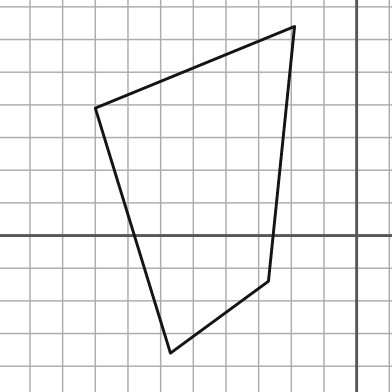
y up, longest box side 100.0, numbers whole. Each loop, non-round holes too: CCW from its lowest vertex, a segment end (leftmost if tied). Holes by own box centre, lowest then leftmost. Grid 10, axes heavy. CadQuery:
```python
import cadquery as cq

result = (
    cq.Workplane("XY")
    .moveTo(-57.0, -36.0)
    .lineTo(-27.0, -14.0)
    .lineTo(-19.0, 64.0)
    .lineTo(-80.0, 39.0)
    .close()
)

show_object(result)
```